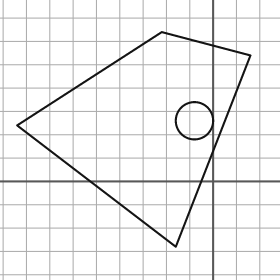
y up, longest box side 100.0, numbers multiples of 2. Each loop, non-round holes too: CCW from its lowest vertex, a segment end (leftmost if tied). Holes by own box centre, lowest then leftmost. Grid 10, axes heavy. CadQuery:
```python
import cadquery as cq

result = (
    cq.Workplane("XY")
    .moveTo(-16.0, -28.0)
    .lineTo(16.0, 54.0)
    .lineTo(-22.0, 64.0)
    .lineTo(-84.0, 24.0)
    .close()
    .moveTo(-8.0, 26.0)
    .circle(8.0)
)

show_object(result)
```